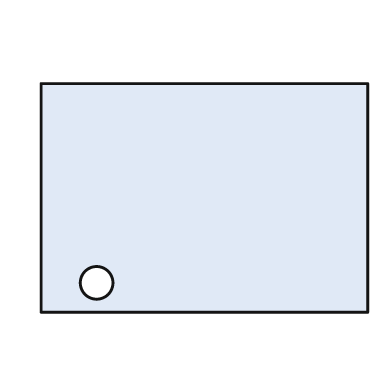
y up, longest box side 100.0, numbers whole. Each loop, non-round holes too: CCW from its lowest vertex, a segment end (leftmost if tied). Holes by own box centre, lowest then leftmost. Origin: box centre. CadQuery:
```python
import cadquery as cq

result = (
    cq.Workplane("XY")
    .moveTo(-50.0, -35.0)
    .lineTo(50.0, -35.0)
    .lineTo(50.0, 35.0)
    .lineTo(-50.0, 35.0)
    .close()
    .moveTo(-33.0, -26.0)
    .circle(5.0)
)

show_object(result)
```